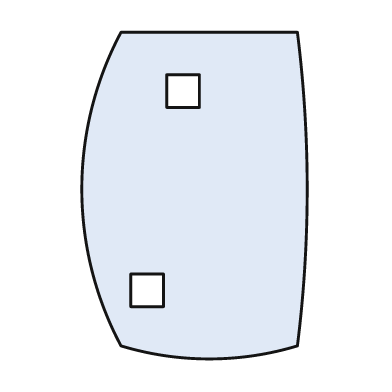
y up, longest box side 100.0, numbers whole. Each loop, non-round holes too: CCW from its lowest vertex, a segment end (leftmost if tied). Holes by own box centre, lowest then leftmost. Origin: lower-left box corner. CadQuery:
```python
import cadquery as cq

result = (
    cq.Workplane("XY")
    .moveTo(12.0, 4.0)
    .threePointArc((39.0, 0.0), (66.0, 4.0))
    .threePointArc((69.0, 52.0), (66.0, 100.0))
    .lineTo(12.0, 100.0)
    .threePointArc((0.0, 52.0), (12.0, 4.0))
    .close()
    .moveTo(15.0, 16.0)
    .lineTo(25.0, 16.0)
    .lineTo(25.0, 26.0)
    .lineTo(15.0, 26.0)
    .close()
    .moveTo(26.0, 77.0)
    .lineTo(36.0, 77.0)
    .lineTo(36.0, 87.0)
    .lineTo(26.0, 87.0)
    .close()
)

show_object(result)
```